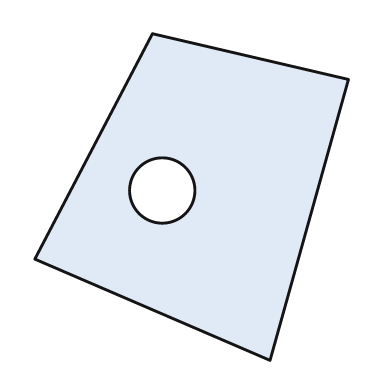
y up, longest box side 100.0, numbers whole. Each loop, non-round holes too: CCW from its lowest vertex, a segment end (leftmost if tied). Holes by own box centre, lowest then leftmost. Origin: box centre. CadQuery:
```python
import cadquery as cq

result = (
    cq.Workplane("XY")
    .moveTo(24.0, -50.0)
    .lineTo(48.0, 36.0)
    .lineTo(-12.0, 50.0)
    .lineTo(-48.0, -19.0)
    .close()
    .moveTo(-9.0, 2.0)
    .circle(10.0)
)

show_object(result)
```